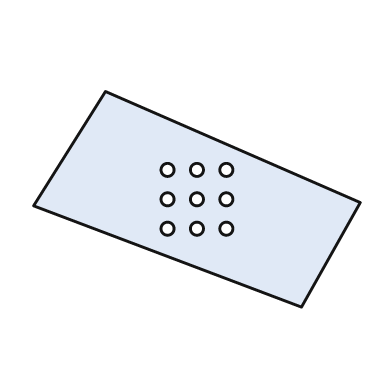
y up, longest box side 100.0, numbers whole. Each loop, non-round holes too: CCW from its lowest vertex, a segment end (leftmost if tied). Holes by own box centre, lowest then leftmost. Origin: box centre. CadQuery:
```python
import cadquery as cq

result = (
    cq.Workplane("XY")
    .moveTo(32.0, -33.0)
    .lineTo(50.0, -1.0)
    .lineTo(-28.0, 33.0)
    .lineTo(-50.0, -2.0)
    .close()
    .moveTo(-9.0, -9.0)
    .circle(2.0)
    .moveTo(0.0, -9.0)
    .circle(2.0)
    .moveTo(9.0, -9.0)
    .circle(2.0)
    .moveTo(-9.0, 0.0)
    .circle(2.0)
    .moveTo(0.0, 0.0)
    .circle(2.0)
    .moveTo(9.0, 0.0)
    .circle(2.0)
    .moveTo(-9.0, 9.0)
    .circle(2.0)
    .moveTo(0.0, 9.0)
    .circle(2.0)
    .moveTo(9.0, 9.0)
    .circle(2.0)
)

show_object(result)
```